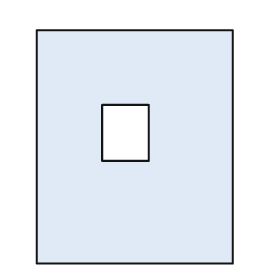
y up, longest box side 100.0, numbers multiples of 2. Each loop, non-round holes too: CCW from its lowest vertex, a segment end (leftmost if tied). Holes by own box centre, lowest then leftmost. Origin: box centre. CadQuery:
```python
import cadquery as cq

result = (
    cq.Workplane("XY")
    .moveTo(-42.0, -50.0)
    .lineTo(42.0, -50.0)
    .lineTo(42.0, 50.0)
    .lineTo(-42.0, 50.0)
    .close()
    .moveTo(-14.0, -6.0)
    .lineTo(6.0, -6.0)
    .lineTo(6.0, 18.0)
    .lineTo(-14.0, 18.0)
    .close()
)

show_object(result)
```